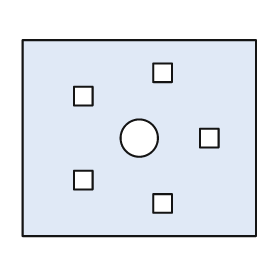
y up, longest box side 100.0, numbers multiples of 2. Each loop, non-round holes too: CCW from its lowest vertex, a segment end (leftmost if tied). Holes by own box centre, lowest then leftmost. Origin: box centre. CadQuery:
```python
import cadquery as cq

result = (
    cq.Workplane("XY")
    .moveTo(-50.0, -42.0)
    .lineTo(50.0, -42.0)
    .lineTo(50.0, 42.0)
    .lineTo(-50.0, 42.0)
    .close()
    .moveTo(6.0, -32.0)
    .lineTo(14.0, -32.0)
    .lineTo(14.0, -24.0)
    .lineTo(6.0, -24.0)
    .close()
    .moveTo(-28.0, -22.0)
    .lineTo(-20.0, -22.0)
    .lineTo(-20.0, -14.0)
    .lineTo(-28.0, -14.0)
    .close()
    .moveTo(0.0, 0.0)
    .circle(8.0)
    .moveTo(26.0, -4.0)
    .lineTo(34.0, -4.0)
    .lineTo(34.0, 4.0)
    .lineTo(26.0, 4.0)
    .close()
    .moveTo(-28.0, 14.0)
    .lineTo(-20.0, 14.0)
    .lineTo(-20.0, 22.0)
    .lineTo(-28.0, 22.0)
    .close()
    .moveTo(6.0, 24.0)
    .lineTo(14.0, 24.0)
    .lineTo(14.0, 32.0)
    .lineTo(6.0, 32.0)
    .close()
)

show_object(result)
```